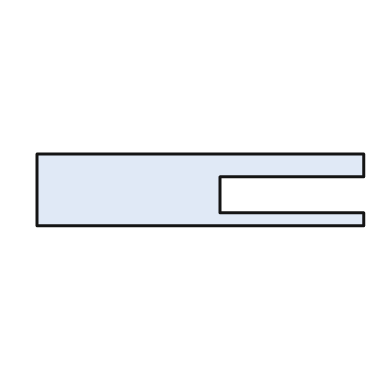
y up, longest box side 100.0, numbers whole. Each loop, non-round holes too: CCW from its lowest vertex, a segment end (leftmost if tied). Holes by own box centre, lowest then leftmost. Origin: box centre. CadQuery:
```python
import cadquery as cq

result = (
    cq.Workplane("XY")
    .moveTo(-50.0, -11.0)
    .lineTo(50.0, -11.0)
    .lineTo(50.0, -7.0)
    .lineTo(6.0, -7.0)
    .lineTo(6.0, 4.0)
    .lineTo(50.0, 4.0)
    .lineTo(50.0, 11.0)
    .lineTo(-50.0, 11.0)
    .close()
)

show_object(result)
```